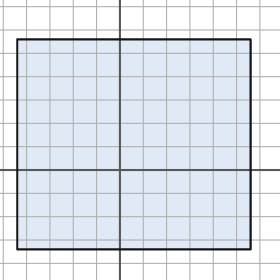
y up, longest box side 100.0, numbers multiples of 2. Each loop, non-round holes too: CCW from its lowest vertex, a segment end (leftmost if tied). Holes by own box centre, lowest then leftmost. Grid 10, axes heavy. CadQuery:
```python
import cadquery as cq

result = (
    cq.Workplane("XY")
    .moveTo(-44.0, -34.0)
    .lineTo(56.0, -34.0)
    .lineTo(56.0, 56.0)
    .lineTo(-44.0, 56.0)
    .close()
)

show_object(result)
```